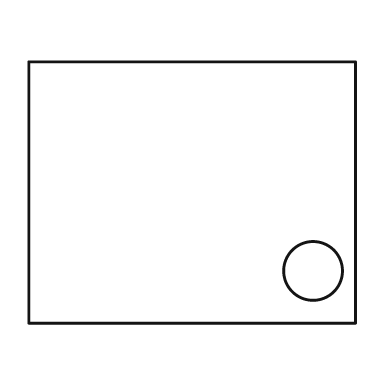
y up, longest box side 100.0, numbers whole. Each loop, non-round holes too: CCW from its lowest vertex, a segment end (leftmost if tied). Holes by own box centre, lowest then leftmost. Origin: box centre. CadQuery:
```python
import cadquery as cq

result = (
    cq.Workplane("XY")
    .moveTo(-50.0, -40.0)
    .lineTo(50.0, -40.0)
    .lineTo(50.0, 40.0)
    .lineTo(-50.0, 40.0)
    .close()
    .moveTo(37.0, -24.0)
    .circle(9.0)
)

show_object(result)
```